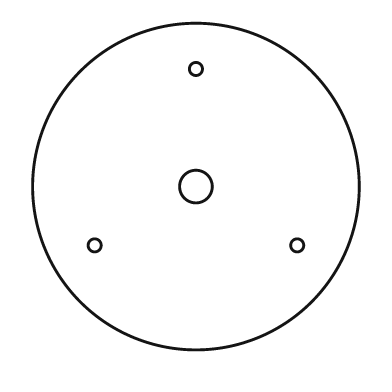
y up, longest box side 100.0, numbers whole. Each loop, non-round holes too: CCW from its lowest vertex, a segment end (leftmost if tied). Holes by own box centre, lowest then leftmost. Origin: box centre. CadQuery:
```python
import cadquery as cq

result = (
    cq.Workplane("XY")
    .moveTo(0.0, 0.0)
    .circle(50.0)
    .moveTo(-31.0, -18.0)
    .circle(2.0)
    .moveTo(31.0, -18.0)
    .circle(2.0)
    .moveTo(0.0, 0.0)
    .circle(5.0)
    .moveTo(0.0, 36.0)
    .circle(2.0)
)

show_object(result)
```